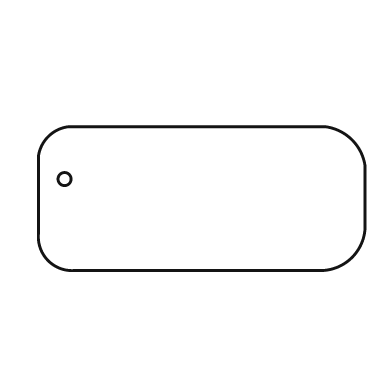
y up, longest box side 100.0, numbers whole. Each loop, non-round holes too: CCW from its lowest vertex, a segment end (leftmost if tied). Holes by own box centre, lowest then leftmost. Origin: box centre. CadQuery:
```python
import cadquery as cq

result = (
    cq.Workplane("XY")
    .moveTo(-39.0, -22.0)
    .lineTo(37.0, -22.0)
    .threePointArc((46.0, -18.0), (50.0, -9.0))
    .lineTo(50.0, 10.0)
    .threePointArc((46.0, 18.0), (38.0, 22.0))
    .lineTo(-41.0, 22.0)
    .threePointArc((-47.0, 19.0), (-50.0, 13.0))
    .lineTo(-50.0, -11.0)
    .threePointArc((-47.0, -19.0), (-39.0, -22.0))
    .close()
    .moveTo(-42.0, 6.0)
    .circle(2.0)
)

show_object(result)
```